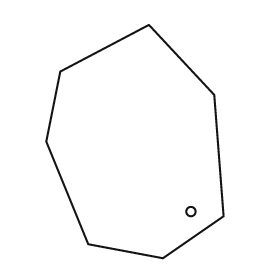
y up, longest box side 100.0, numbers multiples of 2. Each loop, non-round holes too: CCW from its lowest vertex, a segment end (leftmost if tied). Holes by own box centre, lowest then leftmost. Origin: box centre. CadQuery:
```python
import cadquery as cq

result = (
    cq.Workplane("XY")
    .moveTo(12.0, -50.0)
    .lineTo(38.0, -32.0)
    .lineTo(34.0, 20.0)
    .lineTo(6.0, 50.0)
    .lineTo(-32.0, 30.0)
    .lineTo(-38.0, 0.0)
    .lineTo(-20.0, -44.0)
    .close()
    .moveTo(24.0, -30.0)
    .circle(2.0)
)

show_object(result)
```